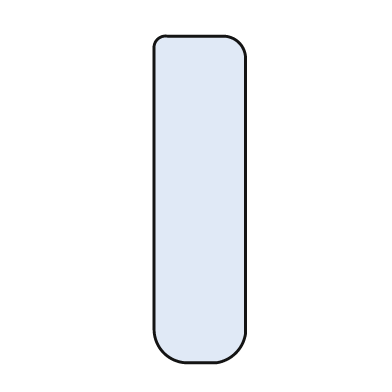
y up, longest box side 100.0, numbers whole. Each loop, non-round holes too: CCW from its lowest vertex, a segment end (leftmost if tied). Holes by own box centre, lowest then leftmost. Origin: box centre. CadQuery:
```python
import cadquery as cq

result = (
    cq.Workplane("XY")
    .moveTo(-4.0, -50.0)
    .lineTo(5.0, -50.0)
    .threePointArc((11.0, -47.0), (14.0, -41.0))
    .lineTo(14.0, 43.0)
    .threePointArc((12.0, 48.0), (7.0, 50.0))
    .lineTo(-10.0, 50.0)
    .threePointArc((-13.0, 49.0), (-14.0, 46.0))
    .lineTo(-14.0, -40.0)
    .threePointArc((-11.0, -47.0), (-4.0, -50.0))
    .close()
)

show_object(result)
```